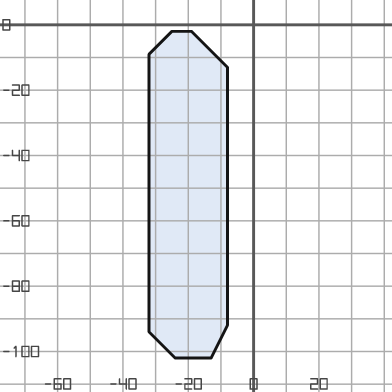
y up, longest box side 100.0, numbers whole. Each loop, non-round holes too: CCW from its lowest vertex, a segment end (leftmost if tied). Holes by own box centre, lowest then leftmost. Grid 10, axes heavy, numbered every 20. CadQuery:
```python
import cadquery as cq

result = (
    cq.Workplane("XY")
    .moveTo(-24.0, -102.0)
    .lineTo(-13.0, -102.0)
    .lineTo(-8.0, -92.0)
    .lineTo(-8.0, -13.0)
    .lineTo(-19.0, -2.0)
    .lineTo(-25.0, -2.0)
    .lineTo(-32.0, -9.0)
    .lineTo(-32.0, -94.0)
    .close()
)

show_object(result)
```